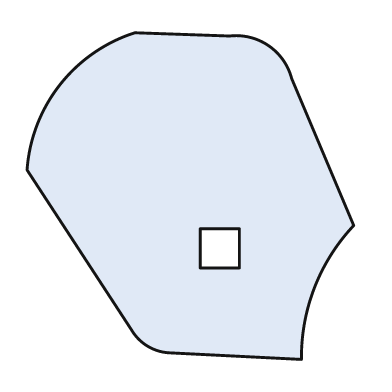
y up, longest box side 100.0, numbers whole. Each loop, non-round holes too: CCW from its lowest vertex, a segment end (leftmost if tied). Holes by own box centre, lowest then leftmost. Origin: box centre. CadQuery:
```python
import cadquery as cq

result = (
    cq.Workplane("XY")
    .moveTo(34.0, -50.0)
    .threePointArc((38.0, -28.0), (50.0, -9.0))
    .lineTo(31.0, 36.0)
    .threePointArc((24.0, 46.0), (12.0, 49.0))
    .lineTo(-17.0, 50.0)
    .threePointArc((-40.0, 34.0), (-50.0, 8.0))
    .lineTo(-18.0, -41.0)
    .threePointArc((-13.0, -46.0), (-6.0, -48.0))
    .close()
    .moveTo(3.0, -22.0)
    .lineTo(15.0, -22.0)
    .lineTo(15.0, -10.0)
    .lineTo(3.0, -10.0)
    .close()
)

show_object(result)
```